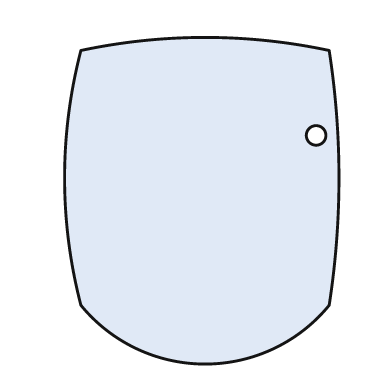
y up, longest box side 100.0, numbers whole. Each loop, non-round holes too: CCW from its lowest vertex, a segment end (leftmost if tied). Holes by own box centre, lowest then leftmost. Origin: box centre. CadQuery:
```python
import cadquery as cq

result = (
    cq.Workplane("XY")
    .moveTo(-37.0, -32.0)
    .threePointArc((1.0, -50.0), (39.0, -32.0))
    .threePointArc((42.0, 7.0), (39.0, 46.0))
    .threePointArc((1.0, 50.0), (-37.0, 46.0))
    .threePointArc((-42.0, 7.0), (-37.0, -32.0))
    .close()
    .moveTo(35.0, 20.0)
    .circle(3.0)
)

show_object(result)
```